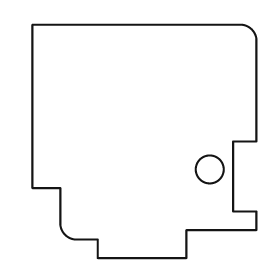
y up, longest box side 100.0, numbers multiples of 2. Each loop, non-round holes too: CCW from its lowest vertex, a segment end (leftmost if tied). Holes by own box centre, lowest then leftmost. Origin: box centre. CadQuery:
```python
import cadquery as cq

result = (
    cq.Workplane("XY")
    .moveTo(-20.0, -50.0)
    .lineTo(18.0, -50.0)
    .lineTo(18.0, -38.0)
    .lineTo(48.0, -38.0)
    .lineTo(48.0, -30.0)
    .lineTo(38.0, -30.0)
    .lineTo(38.0, 0.0)
    .lineTo(48.0, 0.0)
    .lineTo(48.0, 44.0)
    .threePointArc((46.0, 48.0), (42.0, 50.0))
    .lineTo(-48.0, 50.0)
    .lineTo(-48.0, -20.0)
    .lineTo(-36.0, -20.0)
    .lineTo(-36.0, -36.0)
    .threePointArc((-34.0, -40.0), (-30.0, -42.0))
    .lineTo(-20.0, -42.0)
    .close()
    .moveTo(28.0, -12.0)
    .circle(6.0)
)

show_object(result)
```